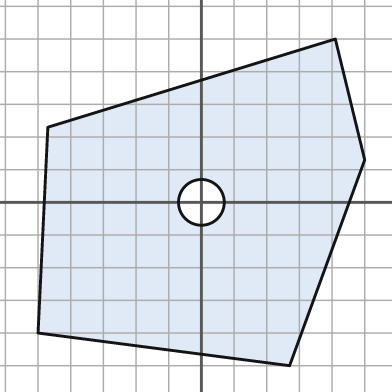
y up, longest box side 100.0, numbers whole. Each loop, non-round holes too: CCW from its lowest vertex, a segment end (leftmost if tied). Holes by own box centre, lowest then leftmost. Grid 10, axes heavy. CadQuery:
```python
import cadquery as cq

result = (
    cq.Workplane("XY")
    .moveTo(27.0, -50.0)
    .lineTo(50.0, 13.0)
    .lineTo(41.0, 50.0)
    .lineTo(-47.0, 23.0)
    .lineTo(-50.0, -40.0)
    .close()
    .moveTo(0.0, 0.0)
    .circle(7.0)
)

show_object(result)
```